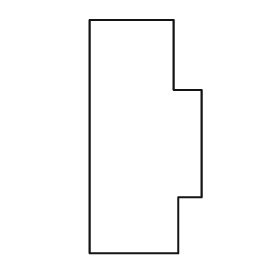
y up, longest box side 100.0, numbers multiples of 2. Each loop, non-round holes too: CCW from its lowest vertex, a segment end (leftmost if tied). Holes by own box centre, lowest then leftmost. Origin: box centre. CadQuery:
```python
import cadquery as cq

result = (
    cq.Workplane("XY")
    .moveTo(-24.0, -50.0)
    .lineTo(14.0, -50.0)
    .lineTo(14.0, -26.0)
    .lineTo(24.0, -26.0)
    .lineTo(24.0, 20.0)
    .lineTo(12.0, 20.0)
    .lineTo(12.0, 50.0)
    .lineTo(-24.0, 50.0)
    .close()
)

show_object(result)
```